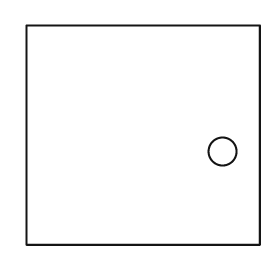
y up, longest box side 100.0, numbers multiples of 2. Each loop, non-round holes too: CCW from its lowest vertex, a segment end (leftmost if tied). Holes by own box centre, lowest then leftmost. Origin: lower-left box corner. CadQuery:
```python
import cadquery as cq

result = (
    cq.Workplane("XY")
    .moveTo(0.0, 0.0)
    .lineTo(100.0, 0.0)
    .lineTo(100.0, 94.0)
    .lineTo(0.0, 94.0)
    .close()
    .moveTo(84.0, 40.0)
    .circle(6.0)
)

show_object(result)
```